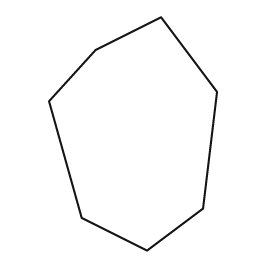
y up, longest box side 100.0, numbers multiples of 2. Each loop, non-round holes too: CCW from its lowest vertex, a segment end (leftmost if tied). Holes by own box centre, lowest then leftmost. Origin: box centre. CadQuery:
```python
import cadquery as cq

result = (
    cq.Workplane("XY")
    .moveTo(6.0, -50.0)
    .lineTo(30.0, -32.0)
    .lineTo(36.0, 18.0)
    .lineTo(12.0, 50.0)
    .lineTo(-16.0, 36.0)
    .lineTo(-36.0, 14.0)
    .lineTo(-22.0, -36.0)
    .close()
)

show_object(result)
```